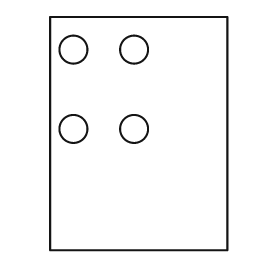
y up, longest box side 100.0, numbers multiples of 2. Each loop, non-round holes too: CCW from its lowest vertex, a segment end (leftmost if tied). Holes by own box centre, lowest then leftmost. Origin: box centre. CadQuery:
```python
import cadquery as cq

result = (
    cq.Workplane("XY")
    .moveTo(-38.0, -50.0)
    .lineTo(38.0, -50.0)
    .lineTo(38.0, 50.0)
    .lineTo(-38.0, 50.0)
    .close()
    .moveTo(-28.0, 2.0)
    .circle(6.0)
    .moveTo(-2.0, 2.0)
    .circle(6.0)
    .moveTo(-28.0, 36.0)
    .circle(6.0)
    .moveTo(-2.0, 36.0)
    .circle(6.0)
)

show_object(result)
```